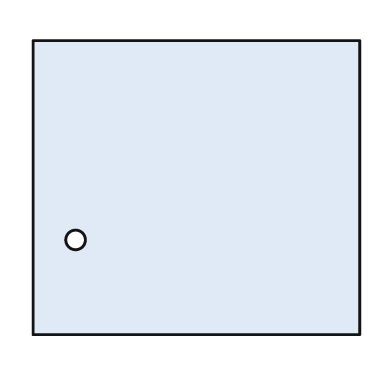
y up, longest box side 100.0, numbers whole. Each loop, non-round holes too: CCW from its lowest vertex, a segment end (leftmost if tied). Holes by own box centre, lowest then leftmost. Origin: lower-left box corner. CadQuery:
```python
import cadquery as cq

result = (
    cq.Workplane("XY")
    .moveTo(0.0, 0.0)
    .lineTo(100.0, 0.0)
    .lineTo(100.0, 90.0)
    .lineTo(0.0, 90.0)
    .close()
    .moveTo(13.0, 29.0)
    .circle(3.0)
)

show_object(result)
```